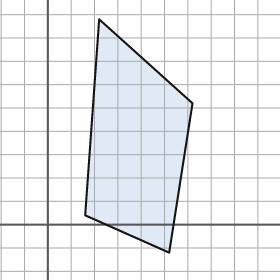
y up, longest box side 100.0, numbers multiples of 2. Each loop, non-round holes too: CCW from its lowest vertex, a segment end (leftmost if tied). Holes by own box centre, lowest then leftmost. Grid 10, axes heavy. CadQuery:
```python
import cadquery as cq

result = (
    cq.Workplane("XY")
    .moveTo(52.0, -12.0)
    .lineTo(62.0, 52.0)
    .lineTo(22.0, 88.0)
    .lineTo(16.0, 4.0)
    .close()
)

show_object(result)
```